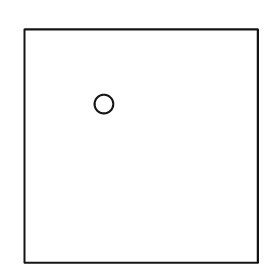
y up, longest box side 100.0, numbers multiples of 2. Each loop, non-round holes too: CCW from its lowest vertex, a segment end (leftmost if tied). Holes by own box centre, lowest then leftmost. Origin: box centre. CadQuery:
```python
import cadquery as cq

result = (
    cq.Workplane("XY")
    .moveTo(-50.0, -50.0)
    .lineTo(50.0, -50.0)
    .lineTo(50.0, 50.0)
    .lineTo(-50.0, 50.0)
    .close()
    .moveTo(-16.0, 18.0)
    .circle(4.0)
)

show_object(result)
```